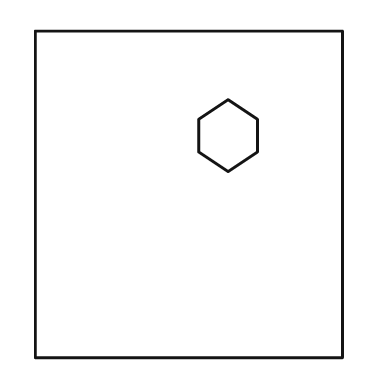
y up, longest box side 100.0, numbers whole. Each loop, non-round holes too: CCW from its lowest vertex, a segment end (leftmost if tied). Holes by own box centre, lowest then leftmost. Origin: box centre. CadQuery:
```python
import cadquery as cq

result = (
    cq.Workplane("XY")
    .moveTo(-47.0, -50.0)
    .lineTo(47.0, -50.0)
    .lineTo(47.0, 50.0)
    .lineTo(-47.0, 50.0)
    .close()
    .moveTo(12.0, 7.0)
    .lineTo(21.0, 13.0)
    .lineTo(21.0, 23.0)
    .lineTo(12.0, 29.0)
    .lineTo(3.0, 23.0)
    .lineTo(3.0, 13.0)
    .close()
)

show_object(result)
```